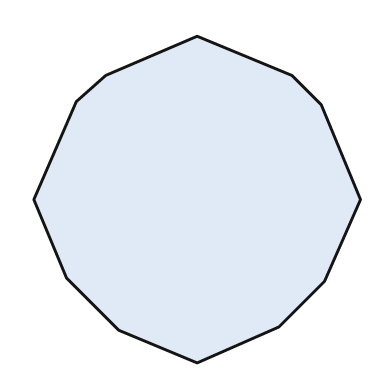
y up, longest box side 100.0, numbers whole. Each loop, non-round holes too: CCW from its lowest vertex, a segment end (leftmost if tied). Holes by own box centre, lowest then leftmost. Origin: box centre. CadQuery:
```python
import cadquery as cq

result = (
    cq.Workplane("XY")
    .moveTo(0.0, -50.0)
    .lineTo(25.0, -39.0)
    .lineTo(39.0, -25.0)
    .lineTo(50.0, 0.0)
    .lineTo(38.0, 29.0)
    .lineTo(29.0, 38.0)
    .lineTo(0.0, 50.0)
    .lineTo(-28.0, 38.0)
    .lineTo(-37.0, 30.0)
    .lineTo(-50.0, 0.0)
    .lineTo(-40.0, -24.0)
    .lineTo(-24.0, -40.0)
    .close()
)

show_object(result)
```